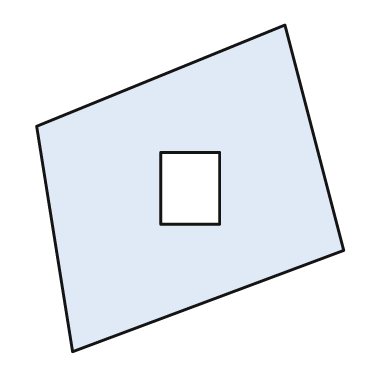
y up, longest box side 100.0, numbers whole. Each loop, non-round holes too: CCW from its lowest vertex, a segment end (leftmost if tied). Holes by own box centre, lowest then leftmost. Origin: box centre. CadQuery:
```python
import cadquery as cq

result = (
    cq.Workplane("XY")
    .moveTo(-36.0, -50.0)
    .lineTo(47.0, -19.0)
    .lineTo(29.0, 50.0)
    .lineTo(-47.0, 19.0)
    .close()
    .moveTo(-9.0, -11.0)
    .lineTo(9.0, -11.0)
    .lineTo(9.0, 11.0)
    .lineTo(-9.0, 11.0)
    .close()
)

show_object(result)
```